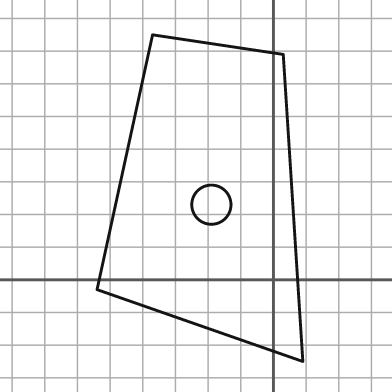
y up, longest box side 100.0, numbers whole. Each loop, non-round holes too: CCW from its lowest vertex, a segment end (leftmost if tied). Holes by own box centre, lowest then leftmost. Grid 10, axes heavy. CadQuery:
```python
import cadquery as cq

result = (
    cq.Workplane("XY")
    .moveTo(9.0, -25.0)
    .lineTo(3.0, 69.0)
    .lineTo(-37.0, 75.0)
    .lineTo(-54.0, -3.0)
    .close()
    .moveTo(-19.0, 23.0)
    .circle(6.0)
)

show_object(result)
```